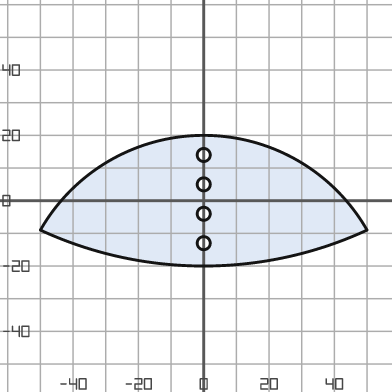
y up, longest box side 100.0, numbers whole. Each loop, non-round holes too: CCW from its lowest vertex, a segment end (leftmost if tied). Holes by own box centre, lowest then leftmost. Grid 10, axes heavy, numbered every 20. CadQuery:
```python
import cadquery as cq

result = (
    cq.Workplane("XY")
    .moveTo(-50.0, -9.0)
    .threePointArc((0.0, -20.0), (50.0, -9.0))
    .threePointArc((0.0, 20.0), (-50.0, -9.0))
    .close()
    .moveTo(0.0, -13.0)
    .circle(2.0)
    .moveTo(0.0, -4.0)
    .circle(2.0)
    .moveTo(0.0, 5.0)
    .circle(2.0)
    .moveTo(0.0, 14.0)
    .circle(2.0)
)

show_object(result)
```